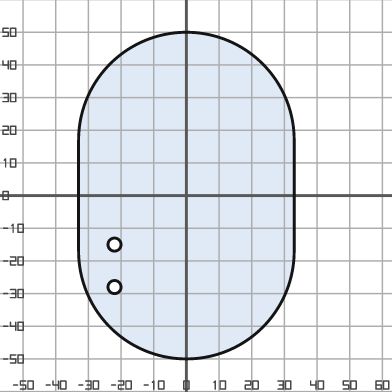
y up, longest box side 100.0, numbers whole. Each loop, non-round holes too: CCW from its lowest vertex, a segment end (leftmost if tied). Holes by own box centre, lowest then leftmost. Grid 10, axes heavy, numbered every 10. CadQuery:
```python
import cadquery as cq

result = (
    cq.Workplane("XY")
    .moveTo(-33.0, -17.0)
    .threePointArc((0.0, -50.0), (33.0, -17.0))
    .lineTo(33.0, 17.0)
    .threePointArc((0.0, 50.0), (-33.0, 17.0))
    .close()
    .moveTo(-22.0, -28.0)
    .circle(2.0)
    .moveTo(-22.0, -15.0)
    .circle(2.0)
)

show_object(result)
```